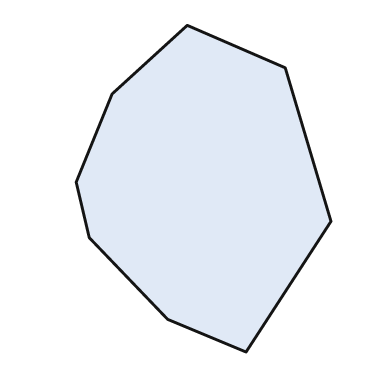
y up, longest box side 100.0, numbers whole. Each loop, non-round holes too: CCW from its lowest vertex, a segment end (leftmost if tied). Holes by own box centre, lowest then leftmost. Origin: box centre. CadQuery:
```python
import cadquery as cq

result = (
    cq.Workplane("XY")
    .moveTo(13.0, -50.0)
    .lineTo(39.0, -10.0)
    .lineTo(25.0, 37.0)
    .lineTo(-5.0, 50.0)
    .lineTo(-28.0, 29.0)
    .lineTo(-39.0, 2.0)
    .lineTo(-35.0, -15.0)
    .lineTo(-11.0, -40.0)
    .close()
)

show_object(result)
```